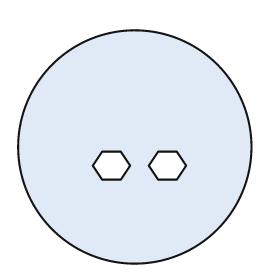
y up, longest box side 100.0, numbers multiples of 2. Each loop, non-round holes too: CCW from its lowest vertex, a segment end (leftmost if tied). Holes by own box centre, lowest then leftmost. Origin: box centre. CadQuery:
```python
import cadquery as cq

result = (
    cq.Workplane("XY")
    .moveTo(0.0, 0.0)
    .circle(50.0)
    .moveTo(-14.0, -14.0)
    .lineTo(-6.0, -14.0)
    .lineTo(-2.0, -8.0)
    .lineTo(-6.0, -2.0)
    .lineTo(-14.0, -2.0)
    .lineTo(-18.0, -8.0)
    .close()
    .moveTo(10.0, -14.0)
    .lineTo(18.0, -14.0)
    .lineTo(22.0, -8.0)
    .lineTo(18.0, -2.0)
    .lineTo(10.0, -2.0)
    .lineTo(6.0, -8.0)
    .close()
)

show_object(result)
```